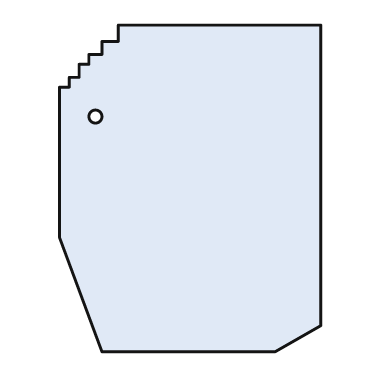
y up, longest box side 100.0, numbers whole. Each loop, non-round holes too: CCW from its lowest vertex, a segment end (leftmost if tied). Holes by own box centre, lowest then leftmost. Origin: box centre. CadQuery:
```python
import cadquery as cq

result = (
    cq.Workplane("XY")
    .moveTo(-27.0, -50.0)
    .lineTo(26.0, -50.0)
    .lineTo(40.0, -42.0)
    .lineTo(40.0, 50.0)
    .lineTo(-22.0, 50.0)
    .lineTo(-22.0, 45.0)
    .lineTo(-27.0, 45.0)
    .lineTo(-27.0, 41.0)
    .lineTo(-31.0, 41.0)
    .lineTo(-31.0, 38.0)
    .lineTo(-34.0, 38.0)
    .lineTo(-34.0, 34.0)
    .lineTo(-37.0, 34.0)
    .lineTo(-37.0, 31.0)
    .lineTo(-40.0, 31.0)
    .lineTo(-40.0, -15.0)
    .close()
    .moveTo(-29.0, 22.0)
    .circle(2.0)
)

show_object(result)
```